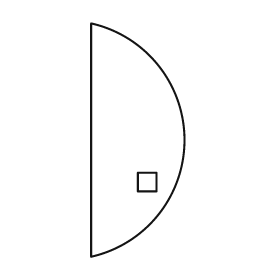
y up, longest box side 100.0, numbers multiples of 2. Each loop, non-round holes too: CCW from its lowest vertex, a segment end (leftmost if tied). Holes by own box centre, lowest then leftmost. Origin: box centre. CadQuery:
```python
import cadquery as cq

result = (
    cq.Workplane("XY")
    .moveTo(-20.0, -50.0)
    .threePointArc((20.0, 0.0), (-20.0, 50.0))
    .close()
    .moveTo(0.0, -22.0)
    .lineTo(8.0, -22.0)
    .lineTo(8.0, -14.0)
    .lineTo(0.0, -14.0)
    .close()
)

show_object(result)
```